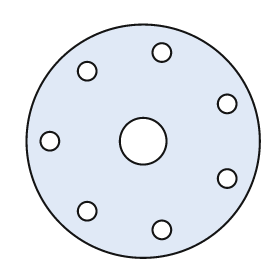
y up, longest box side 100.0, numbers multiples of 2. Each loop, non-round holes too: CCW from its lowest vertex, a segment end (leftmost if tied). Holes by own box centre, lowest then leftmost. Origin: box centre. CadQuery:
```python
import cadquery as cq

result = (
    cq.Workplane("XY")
    .moveTo(0.0, 0.0)
    .circle(50.0)
    .moveTo(8.0, -38.0)
    .circle(4.0)
    .moveTo(-24.0, -30.0)
    .circle(4.0)
    .moveTo(36.0, -16.0)
    .circle(4.0)
    .moveTo(-40.0, 0.0)
    .circle(4.0)
    .moveTo(0.0, 0.0)
    .circle(10.0)
    .moveTo(36.0, 16.0)
    .circle(4.0)
    .moveTo(-24.0, 30.0)
    .circle(4.0)
    .moveTo(8.0, 38.0)
    .circle(4.0)
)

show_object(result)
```